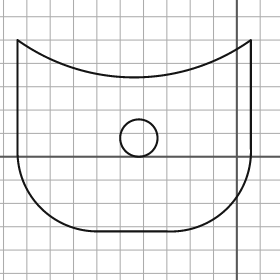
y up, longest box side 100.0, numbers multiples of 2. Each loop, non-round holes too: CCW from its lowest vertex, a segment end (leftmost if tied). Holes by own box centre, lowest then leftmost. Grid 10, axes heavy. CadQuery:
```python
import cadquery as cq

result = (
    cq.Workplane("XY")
    .moveTo(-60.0, -32.0)
    .lineTo(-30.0, -32.0)
    .threePointArc((-4.0, -22.0), (6.0, 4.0))
    .lineTo(6.0, 50.0)
    .threePointArc((-44.0, 34.0), (-94.0, 50.0))
    .lineTo(-94.0, 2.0)
    .threePointArc((-84.0, -22.0), (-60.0, -32.0))
    .close()
    .moveTo(-42.0, 8.0)
    .circle(8.0)
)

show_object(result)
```